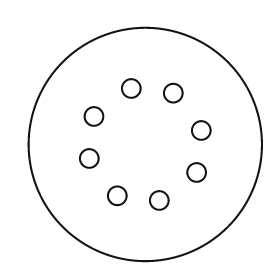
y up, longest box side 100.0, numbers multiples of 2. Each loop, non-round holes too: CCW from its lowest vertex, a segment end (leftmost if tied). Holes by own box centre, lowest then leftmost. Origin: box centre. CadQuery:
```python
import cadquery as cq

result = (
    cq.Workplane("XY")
    .moveTo(0.0, 0.0)
    .circle(50.0)
    .moveTo(6.0, -24.0)
    .circle(4.0)
    .moveTo(-12.0, -22.0)
    .circle(4.0)
    .moveTo(22.0, -12.0)
    .circle(4.0)
    .moveTo(-24.0, -6.0)
    .circle(4.0)
    .moveTo(24.0, 6.0)
    .circle(4.0)
    .moveTo(-22.0, 12.0)
    .circle(4.0)
    .moveTo(12.0, 22.0)
    .circle(4.0)
    .moveTo(-6.0, 24.0)
    .circle(4.0)
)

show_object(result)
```